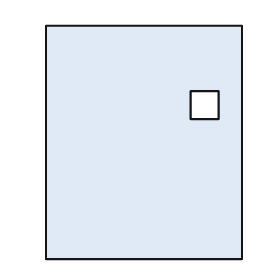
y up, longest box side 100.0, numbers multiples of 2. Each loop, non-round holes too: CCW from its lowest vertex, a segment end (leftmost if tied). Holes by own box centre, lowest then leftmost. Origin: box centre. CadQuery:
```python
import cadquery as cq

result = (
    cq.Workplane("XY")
    .moveTo(-42.0, -50.0)
    .lineTo(42.0, -50.0)
    .lineTo(42.0, 50.0)
    .lineTo(-42.0, 50.0)
    .close()
    .moveTo(20.0, 10.0)
    .lineTo(32.0, 10.0)
    .lineTo(32.0, 22.0)
    .lineTo(20.0, 22.0)
    .close()
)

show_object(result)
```